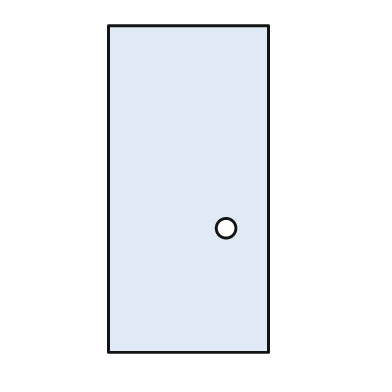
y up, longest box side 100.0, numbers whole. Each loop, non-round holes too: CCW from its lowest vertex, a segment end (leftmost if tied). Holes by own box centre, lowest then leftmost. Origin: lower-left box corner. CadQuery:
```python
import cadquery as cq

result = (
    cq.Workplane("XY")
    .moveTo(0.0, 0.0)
    .lineTo(49.0, 0.0)
    .lineTo(49.0, 100.0)
    .lineTo(0.0, 100.0)
    .close()
    .moveTo(36.0, 38.0)
    .circle(3.0)
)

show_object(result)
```